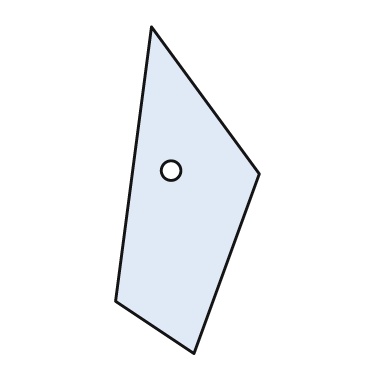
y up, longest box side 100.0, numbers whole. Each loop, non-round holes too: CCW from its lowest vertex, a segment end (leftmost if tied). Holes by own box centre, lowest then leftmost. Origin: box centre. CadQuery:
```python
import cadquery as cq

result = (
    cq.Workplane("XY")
    .moveTo(2.0, -50.0)
    .lineTo(22.0, 5.0)
    .lineTo(-11.0, 50.0)
    .lineTo(-22.0, -34.0)
    .close()
    .moveTo(-5.0, 6.0)
    .circle(3.0)
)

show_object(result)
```